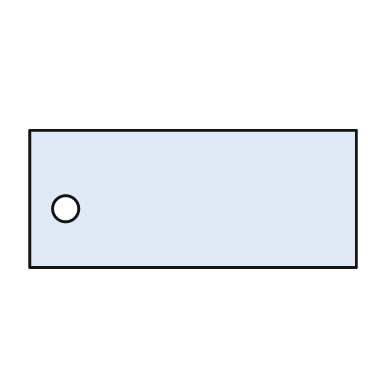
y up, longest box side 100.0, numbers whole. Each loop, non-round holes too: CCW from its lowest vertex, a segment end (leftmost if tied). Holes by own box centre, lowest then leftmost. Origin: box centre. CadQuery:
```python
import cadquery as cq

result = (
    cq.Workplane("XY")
    .moveTo(-50.0, -21.0)
    .lineTo(50.0, -21.0)
    .lineTo(50.0, 21.0)
    .lineTo(-50.0, 21.0)
    .close()
    .moveTo(-39.0, -3.0)
    .circle(4.0)
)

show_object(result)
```